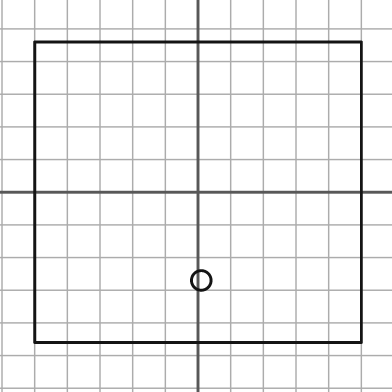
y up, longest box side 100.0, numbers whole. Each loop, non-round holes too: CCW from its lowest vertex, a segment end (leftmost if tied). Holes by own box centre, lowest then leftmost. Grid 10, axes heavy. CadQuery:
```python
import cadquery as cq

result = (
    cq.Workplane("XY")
    .moveTo(-50.0, -46.0)
    .lineTo(50.0, -46.0)
    .lineTo(50.0, 46.0)
    .lineTo(-50.0, 46.0)
    .close()
    .moveTo(1.0, -27.0)
    .circle(3.0)
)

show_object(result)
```